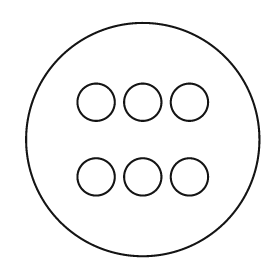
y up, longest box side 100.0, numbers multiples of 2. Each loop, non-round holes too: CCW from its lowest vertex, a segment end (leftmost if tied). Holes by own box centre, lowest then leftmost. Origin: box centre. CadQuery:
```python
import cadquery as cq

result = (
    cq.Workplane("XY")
    .moveTo(0.0, 0.0)
    .circle(50.0)
    .moveTo(-20.0, -16.0)
    .circle(8.0)
    .moveTo(0.0, -16.0)
    .circle(8.0)
    .moveTo(20.0, -16.0)
    .circle(8.0)
    .moveTo(-20.0, 16.0)
    .circle(8.0)
    .moveTo(0.0, 16.0)
    .circle(8.0)
    .moveTo(20.0, 16.0)
    .circle(8.0)
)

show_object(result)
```